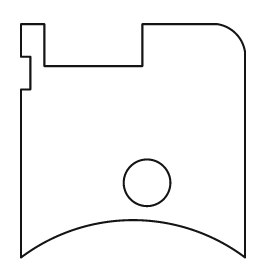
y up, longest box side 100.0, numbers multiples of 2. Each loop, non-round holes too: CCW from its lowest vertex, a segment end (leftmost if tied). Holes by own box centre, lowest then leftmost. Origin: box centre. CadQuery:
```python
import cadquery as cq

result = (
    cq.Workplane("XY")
    .moveTo(-48.0, -50.0)
    .threePointArc((0.0, -34.0), (48.0, -50.0))
    .lineTo(48.0, 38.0)
    .threePointArc((44.0, 46.0), (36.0, 50.0))
    .lineTo(4.0, 50.0)
    .lineTo(4.0, 32.0)
    .lineTo(-38.0, 32.0)
    .lineTo(-38.0, 50.0)
    .lineTo(-48.0, 50.0)
    .lineTo(-48.0, 36.0)
    .lineTo(-44.0, 36.0)
    .lineTo(-44.0, 22.0)
    .lineTo(-48.0, 22.0)
    .close()
    .moveTo(6.0, -18.0)
    .circle(10.0)
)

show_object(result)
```